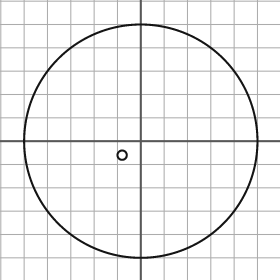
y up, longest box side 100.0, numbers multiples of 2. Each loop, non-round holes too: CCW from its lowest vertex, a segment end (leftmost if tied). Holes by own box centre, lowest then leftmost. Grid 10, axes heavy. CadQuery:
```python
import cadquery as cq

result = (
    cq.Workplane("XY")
    .moveTo(0.0, 0.0)
    .circle(50.0)
    .moveTo(-8.0, -6.0)
    .circle(2.0)
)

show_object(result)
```